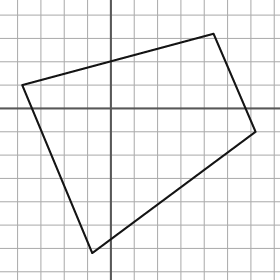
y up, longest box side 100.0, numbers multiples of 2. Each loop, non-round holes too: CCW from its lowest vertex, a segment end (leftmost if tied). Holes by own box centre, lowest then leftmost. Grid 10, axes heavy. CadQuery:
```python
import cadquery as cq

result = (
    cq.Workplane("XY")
    .moveTo(-8.0, -62.0)
    .lineTo(62.0, -10.0)
    .lineTo(44.0, 32.0)
    .lineTo(-38.0, 10.0)
    .close()
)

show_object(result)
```